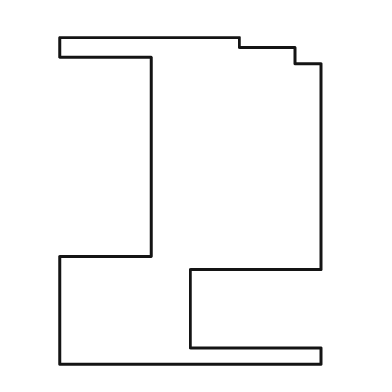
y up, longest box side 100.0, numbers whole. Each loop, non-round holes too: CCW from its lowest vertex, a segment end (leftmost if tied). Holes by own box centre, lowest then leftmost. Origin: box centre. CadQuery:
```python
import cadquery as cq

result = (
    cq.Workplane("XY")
    .moveTo(-40.0, -50.0)
    .lineTo(40.0, -50.0)
    .lineTo(40.0, -45.0)
    .lineTo(0.0, -45.0)
    .lineTo(0.0, -21.0)
    .lineTo(40.0, -21.0)
    .lineTo(40.0, 42.0)
    .lineTo(32.0, 42.0)
    .lineTo(32.0, 47.0)
    .lineTo(15.0, 47.0)
    .lineTo(15.0, 50.0)
    .lineTo(-40.0, 50.0)
    .lineTo(-40.0, 44.0)
    .lineTo(-12.0, 44.0)
    .lineTo(-12.0, -17.0)
    .lineTo(-40.0, -17.0)
    .close()
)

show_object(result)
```